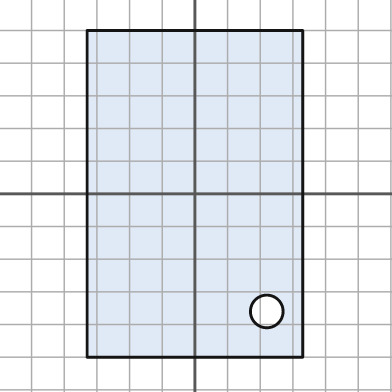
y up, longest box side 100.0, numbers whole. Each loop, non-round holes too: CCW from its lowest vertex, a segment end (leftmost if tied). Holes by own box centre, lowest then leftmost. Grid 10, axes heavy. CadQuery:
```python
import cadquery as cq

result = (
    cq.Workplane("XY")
    .moveTo(-33.0, -50.0)
    .lineTo(33.0, -50.0)
    .lineTo(33.0, 50.0)
    .lineTo(-33.0, 50.0)
    .close()
    .moveTo(22.0, -36.0)
    .circle(5.0)
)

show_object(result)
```